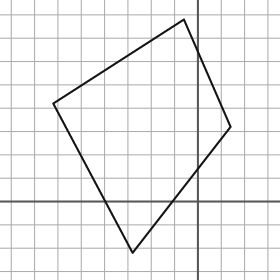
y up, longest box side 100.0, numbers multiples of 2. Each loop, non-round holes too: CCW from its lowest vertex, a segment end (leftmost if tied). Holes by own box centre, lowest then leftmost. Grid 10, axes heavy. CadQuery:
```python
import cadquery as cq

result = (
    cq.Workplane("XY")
    .moveTo(-28.0, -22.0)
    .lineTo(14.0, 32.0)
    .lineTo(-6.0, 78.0)
    .lineTo(-62.0, 42.0)
    .close()
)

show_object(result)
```